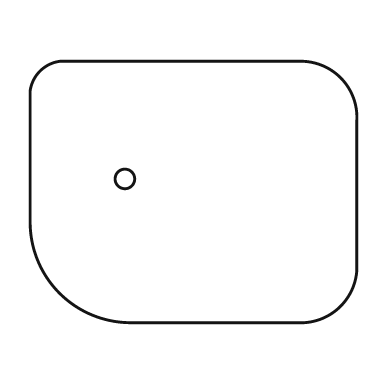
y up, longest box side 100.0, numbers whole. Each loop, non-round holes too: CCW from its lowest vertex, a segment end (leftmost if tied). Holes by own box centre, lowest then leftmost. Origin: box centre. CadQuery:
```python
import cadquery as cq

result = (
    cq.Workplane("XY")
    .moveTo(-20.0, -40.0)
    .lineTo(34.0, -40.0)
    .threePointArc((45.0, -35.0), (50.0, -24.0))
    .lineTo(50.0, 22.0)
    .threePointArc((45.0, 35.0), (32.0, 40.0))
    .lineTo(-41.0, 40.0)
    .threePointArc((-47.0, 37.0), (-50.0, 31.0))
    .lineTo(-50.0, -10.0)
    .threePointArc((-41.0, -31.0), (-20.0, -40.0))
    .close()
    .moveTo(-21.0, 4.0)
    .circle(3.0)
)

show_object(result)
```